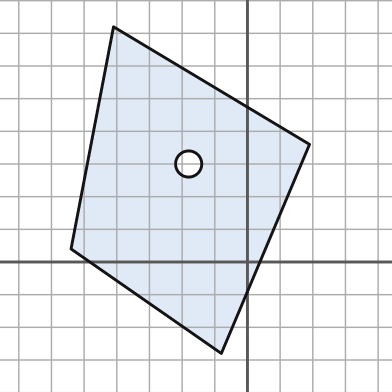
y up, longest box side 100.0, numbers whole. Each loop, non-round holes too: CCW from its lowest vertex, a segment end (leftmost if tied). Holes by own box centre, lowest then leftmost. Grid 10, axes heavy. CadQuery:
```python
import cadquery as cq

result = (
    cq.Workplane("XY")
    .moveTo(-8.0, -28.0)
    .lineTo(19.0, 36.0)
    .lineTo(-41.0, 72.0)
    .lineTo(-54.0, 4.0)
    .close()
    .moveTo(-18.0, 30.0)
    .circle(4.0)
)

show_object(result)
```